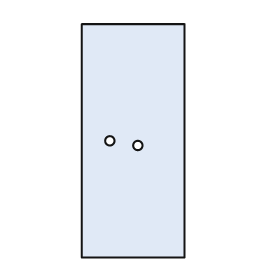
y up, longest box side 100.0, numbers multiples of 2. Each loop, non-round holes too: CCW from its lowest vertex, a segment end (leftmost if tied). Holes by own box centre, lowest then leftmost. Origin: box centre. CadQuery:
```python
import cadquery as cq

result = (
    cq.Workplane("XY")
    .moveTo(-22.0, -50.0)
    .lineTo(22.0, -50.0)
    .lineTo(22.0, 50.0)
    .lineTo(-22.0, 50.0)
    .close()
    .moveTo(2.0, -2.0)
    .circle(2.0)
    .moveTo(-10.0, 0.0)
    .circle(2.0)
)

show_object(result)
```